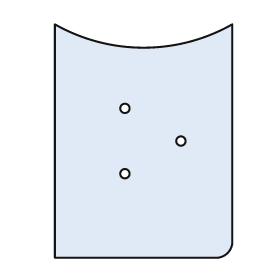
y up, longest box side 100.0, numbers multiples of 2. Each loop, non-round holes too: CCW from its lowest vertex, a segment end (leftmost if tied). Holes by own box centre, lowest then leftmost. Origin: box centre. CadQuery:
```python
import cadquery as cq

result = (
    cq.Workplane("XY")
    .moveTo(-38.0, -50.0)
    .lineTo(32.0, -50.0)
    .threePointArc((36.0, -48.0), (38.0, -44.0))
    .lineTo(38.0, 50.0)
    .threePointArc((0.0, 40.0), (-38.0, 50.0))
    .close()
    .moveTo(-8.0, -14.0)
    .circle(2.0)
    .moveTo(16.0, 0.0)
    .circle(2.0)
    .moveTo(-8.0, 14.0)
    .circle(2.0)
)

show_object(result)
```